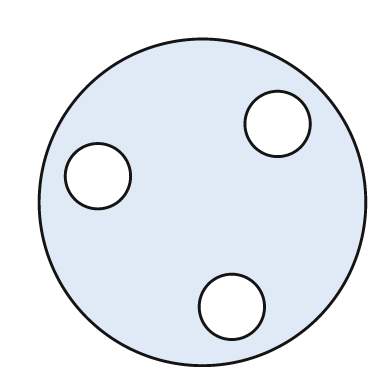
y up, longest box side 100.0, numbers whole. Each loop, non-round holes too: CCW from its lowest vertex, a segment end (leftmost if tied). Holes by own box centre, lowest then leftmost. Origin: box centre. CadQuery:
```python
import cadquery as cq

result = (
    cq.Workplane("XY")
    .moveTo(0.0, 0.0)
    .circle(50.0)
    .moveTo(9.0, -32.0)
    .circle(10.0)
    .moveTo(-32.0, 8.0)
    .circle(10.0)
    .moveTo(23.0, 24.0)
    .circle(10.0)
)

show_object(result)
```